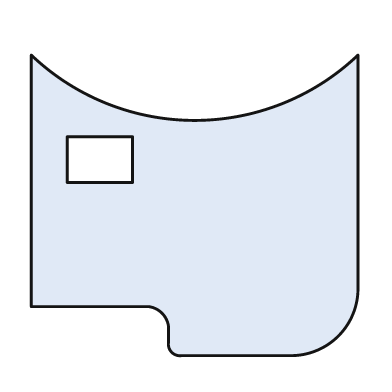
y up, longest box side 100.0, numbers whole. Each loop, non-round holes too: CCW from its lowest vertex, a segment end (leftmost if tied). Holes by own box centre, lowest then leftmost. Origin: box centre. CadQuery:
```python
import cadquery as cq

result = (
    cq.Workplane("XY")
    .moveTo(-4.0, -46.0)
    .lineTo(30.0, -46.0)
    .threePointArc((44.0, -40.0), (50.0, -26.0))
    .lineTo(50.0, 46.0)
    .threePointArc((0.0, 26.0), (-50.0, 46.0))
    .lineTo(-50.0, -31.0)
    .lineTo(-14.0, -31.0)
    .threePointArc((-10.0, -33.0), (-8.0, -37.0))
    .lineTo(-8.0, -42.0)
    .threePointArc((-7.0, -45.0), (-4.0, -46.0))
    .close()
    .moveTo(-39.0, 7.0)
    .lineTo(-19.0, 7.0)
    .lineTo(-19.0, 21.0)
    .lineTo(-39.0, 21.0)
    .close()
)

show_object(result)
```